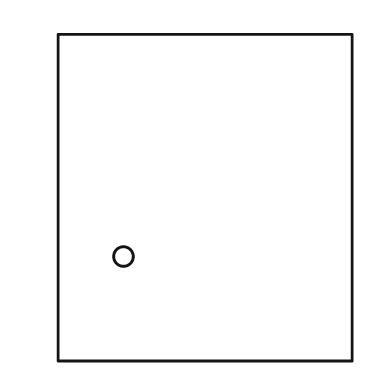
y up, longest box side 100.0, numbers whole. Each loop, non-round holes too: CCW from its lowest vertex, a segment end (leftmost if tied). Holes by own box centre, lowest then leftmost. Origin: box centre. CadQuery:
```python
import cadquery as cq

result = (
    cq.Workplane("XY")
    .moveTo(-45.0, -50.0)
    .lineTo(45.0, -50.0)
    .lineTo(45.0, 50.0)
    .lineTo(-45.0, 50.0)
    .close()
    .moveTo(-25.0, -18.0)
    .circle(3.0)
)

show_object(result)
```